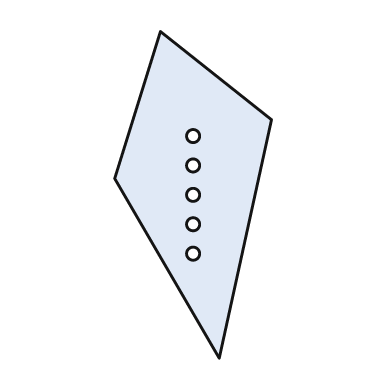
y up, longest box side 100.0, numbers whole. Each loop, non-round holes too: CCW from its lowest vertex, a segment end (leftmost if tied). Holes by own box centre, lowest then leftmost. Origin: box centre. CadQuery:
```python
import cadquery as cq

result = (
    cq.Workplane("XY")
    .moveTo(8.0, -50.0)
    .lineTo(24.0, 23.0)
    .lineTo(-10.0, 50.0)
    .lineTo(-24.0, 5.0)
    .close()
    .moveTo(0.0, -18.0)
    .circle(2.0)
    .moveTo(0.0, -9.0)
    .circle(2.0)
    .moveTo(0.0, 0.0)
    .circle(2.0)
    .moveTo(0.0, 9.0)
    .circle(2.0)
    .moveTo(0.0, 18.0)
    .circle(2.0)
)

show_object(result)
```